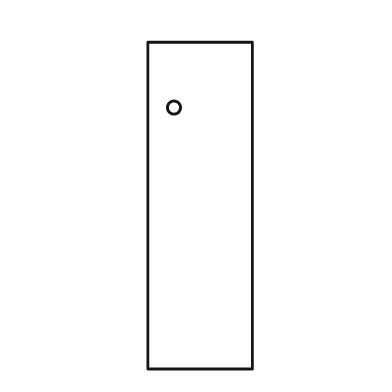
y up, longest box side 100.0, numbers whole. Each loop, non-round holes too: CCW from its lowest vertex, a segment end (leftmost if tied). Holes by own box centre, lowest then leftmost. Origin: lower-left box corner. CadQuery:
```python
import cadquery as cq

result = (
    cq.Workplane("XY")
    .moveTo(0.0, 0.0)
    .lineTo(32.0, 0.0)
    .lineTo(32.0, 100.0)
    .lineTo(0.0, 100.0)
    .close()
    .moveTo(8.0, 80.0)
    .circle(2.0)
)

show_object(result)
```